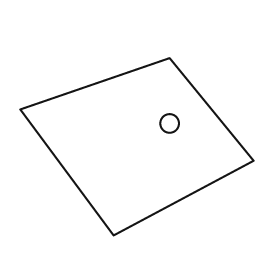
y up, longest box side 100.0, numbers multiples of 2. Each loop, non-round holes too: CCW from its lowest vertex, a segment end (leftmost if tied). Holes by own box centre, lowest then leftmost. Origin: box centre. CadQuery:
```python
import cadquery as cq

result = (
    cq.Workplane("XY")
    .moveTo(-10.0, -38.0)
    .lineTo(50.0, -6.0)
    .lineTo(14.0, 38.0)
    .lineTo(-50.0, 16.0)
    .close()
    .moveTo(14.0, 10.0)
    .circle(4.0)
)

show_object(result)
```